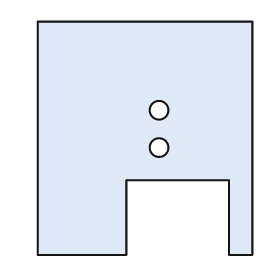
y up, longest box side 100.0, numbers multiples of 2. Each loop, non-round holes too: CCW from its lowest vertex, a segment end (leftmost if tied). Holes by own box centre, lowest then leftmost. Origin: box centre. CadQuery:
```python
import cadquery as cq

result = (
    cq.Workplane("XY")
    .moveTo(-46.0, -50.0)
    .lineTo(-8.0, -50.0)
    .lineTo(-8.0, -18.0)
    .lineTo(36.0, -18.0)
    .lineTo(36.0, -50.0)
    .lineTo(46.0, -50.0)
    .lineTo(46.0, 50.0)
    .lineTo(-46.0, 50.0)
    .close()
    .moveTo(6.0, -4.0)
    .circle(4.0)
    .moveTo(6.0, 12.0)
    .circle(4.0)
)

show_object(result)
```